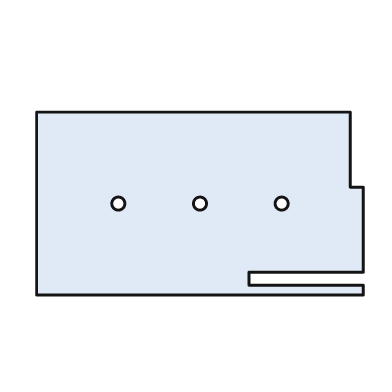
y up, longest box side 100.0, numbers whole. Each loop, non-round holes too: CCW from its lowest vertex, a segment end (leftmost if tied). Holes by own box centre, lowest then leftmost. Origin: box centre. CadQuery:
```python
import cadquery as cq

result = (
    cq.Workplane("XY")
    .moveTo(-50.0, -28.0)
    .lineTo(50.0, -28.0)
    .lineTo(50.0, -25.0)
    .lineTo(15.0, -25.0)
    .lineTo(15.0, -21.0)
    .lineTo(50.0, -21.0)
    .lineTo(50.0, 5.0)
    .lineTo(46.0, 5.0)
    .lineTo(46.0, 28.0)
    .lineTo(-50.0, 28.0)
    .close()
    .moveTo(-25.0, 0.0)
    .circle(2.0)
    .moveTo(0.0, 0.0)
    .circle(2.0)
    .moveTo(25.0, 0.0)
    .circle(2.0)
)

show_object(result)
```